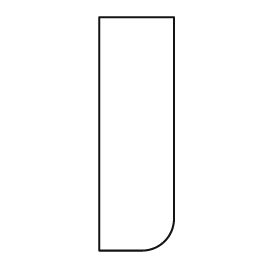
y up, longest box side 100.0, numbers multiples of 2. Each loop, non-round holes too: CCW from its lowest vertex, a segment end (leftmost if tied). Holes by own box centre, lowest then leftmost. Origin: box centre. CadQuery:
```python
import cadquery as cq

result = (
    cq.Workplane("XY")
    .moveTo(-16.0, -50.0)
    .lineTo(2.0, -50.0)
    .threePointArc((12.0, -46.0), (16.0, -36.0))
    .lineTo(16.0, 50.0)
    .lineTo(-16.0, 50.0)
    .close()
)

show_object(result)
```